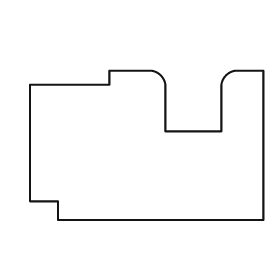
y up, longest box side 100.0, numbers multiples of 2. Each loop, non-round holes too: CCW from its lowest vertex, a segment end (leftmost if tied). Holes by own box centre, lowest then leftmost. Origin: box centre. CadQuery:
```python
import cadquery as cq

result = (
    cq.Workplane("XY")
    .moveTo(-38.0, -32.0)
    .lineTo(50.0, -32.0)
    .lineTo(50.0, 32.0)
    .lineTo(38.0, 32.0)
    .threePointArc((34.0, 30.0), (32.0, 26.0))
    .lineTo(32.0, 6.0)
    .lineTo(8.0, 6.0)
    .lineTo(8.0, 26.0)
    .threePointArc((6.0, 30.0), (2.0, 32.0))
    .lineTo(-16.0, 32.0)
    .lineTo(-16.0, 26.0)
    .lineTo(-50.0, 26.0)
    .lineTo(-50.0, -24.0)
    .lineTo(-38.0, -24.0)
    .close()
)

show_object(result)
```